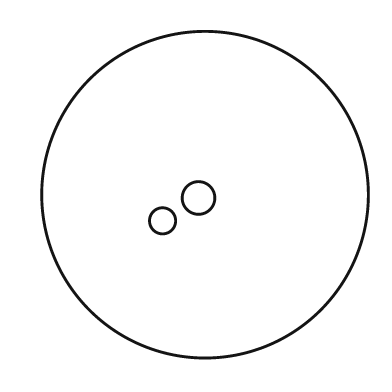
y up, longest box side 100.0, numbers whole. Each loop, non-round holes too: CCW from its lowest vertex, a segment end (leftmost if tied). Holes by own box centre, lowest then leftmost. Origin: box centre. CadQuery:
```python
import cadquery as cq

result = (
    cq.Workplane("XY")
    .moveTo(0.0, 0.0)
    .circle(50.0)
    .moveTo(-13.0, -8.0)
    .circle(4.0)
    .moveTo(-2.0, -1.0)
    .circle(5.0)
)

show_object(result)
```